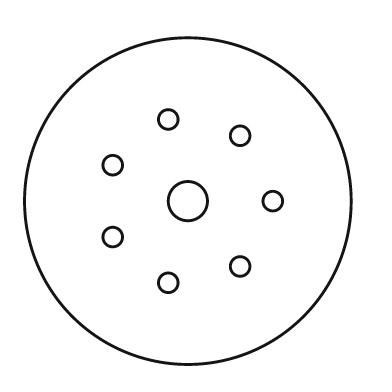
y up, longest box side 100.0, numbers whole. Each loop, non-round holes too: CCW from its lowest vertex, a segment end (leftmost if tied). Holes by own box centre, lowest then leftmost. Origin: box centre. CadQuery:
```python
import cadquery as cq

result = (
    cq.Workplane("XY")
    .moveTo(0.0, 0.0)
    .circle(50.0)
    .moveTo(-6.0, -25.0)
    .circle(3.0)
    .moveTo(16.0, -20.0)
    .circle(3.0)
    .moveTo(-23.0, -11.0)
    .circle(3.0)
    .moveTo(0.0, 0.0)
    .circle(6.0)
    .moveTo(26.0, 0.0)
    .circle(3.0)
    .moveTo(-23.0, 11.0)
    .circle(3.0)
    .moveTo(16.0, 20.0)
    .circle(3.0)
    .moveTo(-6.0, 25.0)
    .circle(3.0)
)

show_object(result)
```